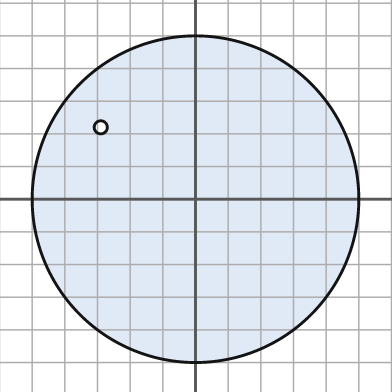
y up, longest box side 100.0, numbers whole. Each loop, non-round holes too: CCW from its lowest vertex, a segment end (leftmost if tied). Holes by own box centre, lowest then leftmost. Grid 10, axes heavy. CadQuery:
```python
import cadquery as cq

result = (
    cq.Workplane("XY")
    .moveTo(0.0, 0.0)
    .circle(50.0)
    .moveTo(-29.0, 22.0)
    .circle(2.0)
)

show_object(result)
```